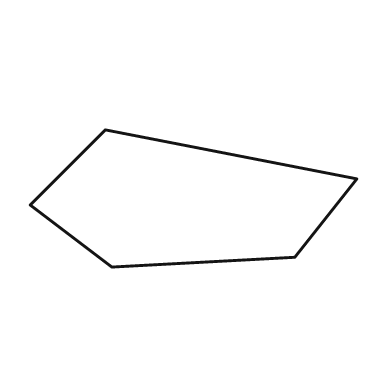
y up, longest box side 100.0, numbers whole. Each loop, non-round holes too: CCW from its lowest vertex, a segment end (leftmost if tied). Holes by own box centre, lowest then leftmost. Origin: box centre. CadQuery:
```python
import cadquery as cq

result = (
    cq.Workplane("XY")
    .moveTo(-25.0, -21.0)
    .lineTo(31.0, -18.0)
    .lineTo(50.0, 6.0)
    .lineTo(-27.0, 21.0)
    .lineTo(-50.0, -2.0)
    .close()
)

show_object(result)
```